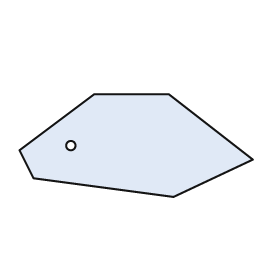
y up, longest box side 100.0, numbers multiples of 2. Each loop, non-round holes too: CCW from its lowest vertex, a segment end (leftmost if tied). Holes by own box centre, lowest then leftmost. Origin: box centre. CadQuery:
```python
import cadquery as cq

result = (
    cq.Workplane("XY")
    .moveTo(16.0, -22.0)
    .lineTo(50.0, -6.0)
    .lineTo(14.0, 22.0)
    .lineTo(-18.0, 22.0)
    .lineTo(-50.0, -2.0)
    .lineTo(-44.0, -14.0)
    .close()
    .moveTo(-28.0, 0.0)
    .circle(2.0)
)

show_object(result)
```